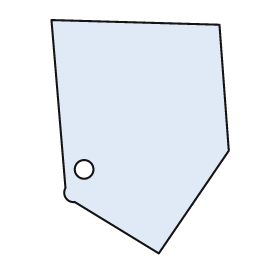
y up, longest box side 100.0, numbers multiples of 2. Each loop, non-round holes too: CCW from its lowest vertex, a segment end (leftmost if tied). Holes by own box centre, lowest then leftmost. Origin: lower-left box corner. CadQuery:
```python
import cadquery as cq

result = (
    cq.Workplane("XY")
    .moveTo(46.0, 0.0)
    .lineTo(76.0, 44.0)
    .lineTo(72.0, 98.0)
    .lineTo(0.0, 100.0)
    .lineTo(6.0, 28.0)
    .threePointArc((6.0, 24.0), (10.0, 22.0))
    .close()
    .moveTo(14.0, 36.0)
    .circle(4.0)
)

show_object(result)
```